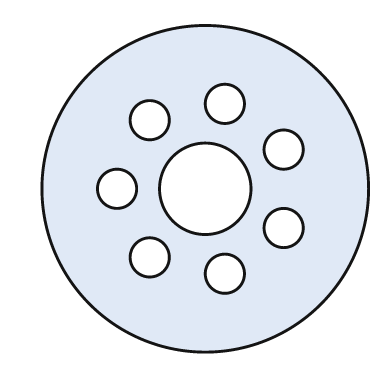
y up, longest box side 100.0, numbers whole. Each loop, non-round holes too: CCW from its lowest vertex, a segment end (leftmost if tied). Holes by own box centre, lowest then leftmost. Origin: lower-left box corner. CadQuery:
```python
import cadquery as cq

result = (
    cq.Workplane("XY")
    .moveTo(50.0, 50.0)
    .circle(50.0)
    .moveTo(56.0, 24.0)
    .circle(6.0)
    .moveTo(33.0, 29.0)
    .circle(6.0)
    .moveTo(74.0, 38.0)
    .circle(6.0)
    .moveTo(23.0, 50.0)
    .circle(6.0)
    .moveTo(50.0, 50.0)
    .circle(14.0)
    .moveTo(74.0, 62.0)
    .circle(6.0)
    .moveTo(33.0, 71.0)
    .circle(6.0)
    .moveTo(56.0, 76.0)
    .circle(6.0)
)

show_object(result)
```